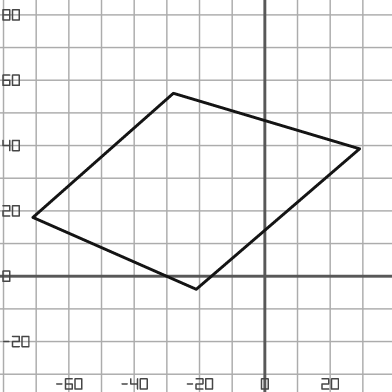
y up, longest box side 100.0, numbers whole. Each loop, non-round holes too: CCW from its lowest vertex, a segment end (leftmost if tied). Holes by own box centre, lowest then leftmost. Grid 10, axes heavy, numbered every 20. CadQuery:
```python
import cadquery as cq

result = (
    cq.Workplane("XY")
    .moveTo(-21.0, -4.0)
    .lineTo(29.0, 39.0)
    .lineTo(-28.0, 56.0)
    .lineTo(-71.0, 18.0)
    .close()
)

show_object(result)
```